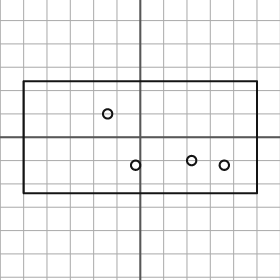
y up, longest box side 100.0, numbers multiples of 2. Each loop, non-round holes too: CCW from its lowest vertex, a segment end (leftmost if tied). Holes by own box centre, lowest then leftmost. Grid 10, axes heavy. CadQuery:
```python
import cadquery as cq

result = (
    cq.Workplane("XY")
    .moveTo(-50.0, -24.0)
    .lineTo(50.0, -24.0)
    .lineTo(50.0, 24.0)
    .lineTo(-50.0, 24.0)
    .close()
    .moveTo(-2.0, -12.0)
    .circle(2.0)
    .moveTo(36.0, -12.0)
    .circle(2.0)
    .moveTo(22.0, -10.0)
    .circle(2.0)
    .moveTo(-14.0, 10.0)
    .circle(2.0)
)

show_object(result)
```